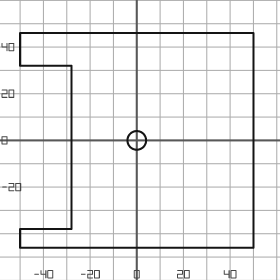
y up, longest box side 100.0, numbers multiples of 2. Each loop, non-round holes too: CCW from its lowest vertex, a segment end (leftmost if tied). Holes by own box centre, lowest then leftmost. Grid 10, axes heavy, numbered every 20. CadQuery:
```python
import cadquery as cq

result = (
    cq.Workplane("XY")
    .moveTo(-50.0, -46.0)
    .lineTo(50.0, -46.0)
    .lineTo(50.0, 46.0)
    .lineTo(-50.0, 46.0)
    .lineTo(-50.0, 32.0)
    .lineTo(-28.0, 32.0)
    .lineTo(-28.0, -38.0)
    .lineTo(-50.0, -38.0)
    .close()
    .moveTo(0.0, 0.0)
    .circle(4.0)
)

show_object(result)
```